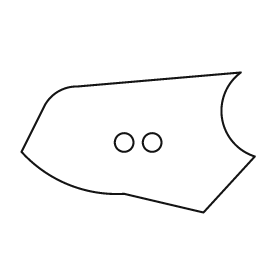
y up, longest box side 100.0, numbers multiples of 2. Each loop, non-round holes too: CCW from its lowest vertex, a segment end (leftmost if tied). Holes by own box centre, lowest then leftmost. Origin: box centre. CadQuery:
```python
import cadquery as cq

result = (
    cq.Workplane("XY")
    .moveTo(28.0, -30.0)
    .lineTo(50.0, -6.0)
    .threePointArc((36.0, 10.0), (44.0, 30.0))
    .lineTo(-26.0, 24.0)
    .threePointArc((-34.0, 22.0), (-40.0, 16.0))
    .lineTo(-50.0, -4.0)
    .threePointArc((-30.0, -18.0), (-6.0, -22.0))
    .close()
    .moveTo(-6.0, 0.0)
    .circle(4.0)
    .moveTo(6.0, 0.0)
    .circle(4.0)
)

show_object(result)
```